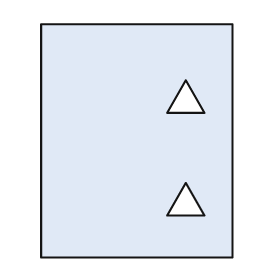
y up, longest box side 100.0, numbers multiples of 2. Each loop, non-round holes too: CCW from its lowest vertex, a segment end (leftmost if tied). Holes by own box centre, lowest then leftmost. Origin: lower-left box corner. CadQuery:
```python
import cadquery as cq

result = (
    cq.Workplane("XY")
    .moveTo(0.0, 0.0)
    .lineTo(82.0, 0.0)
    .lineTo(82.0, 100.0)
    .lineTo(0.0, 100.0)
    .close()
    .moveTo(54.0, 18.0)
    .lineTo(70.0, 18.0)
    .lineTo(62.0, 32.0)
    .close()
    .moveTo(54.0, 62.0)
    .lineTo(70.0, 62.0)
    .lineTo(62.0, 76.0)
    .close()
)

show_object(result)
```